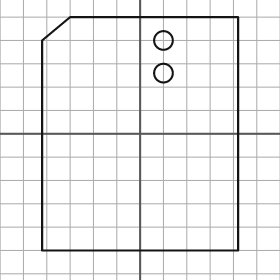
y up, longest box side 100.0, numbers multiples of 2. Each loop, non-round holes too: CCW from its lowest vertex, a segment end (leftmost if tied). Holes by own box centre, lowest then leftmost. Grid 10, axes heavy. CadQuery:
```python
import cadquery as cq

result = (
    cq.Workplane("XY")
    .moveTo(-42.0, -50.0)
    .lineTo(42.0, -50.0)
    .lineTo(42.0, 50.0)
    .lineTo(-30.0, 50.0)
    .lineTo(-42.0, 40.0)
    .close()
    .moveTo(10.0, 26.0)
    .circle(4.0)
    .moveTo(10.0, 40.0)
    .circle(4.0)
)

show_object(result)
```